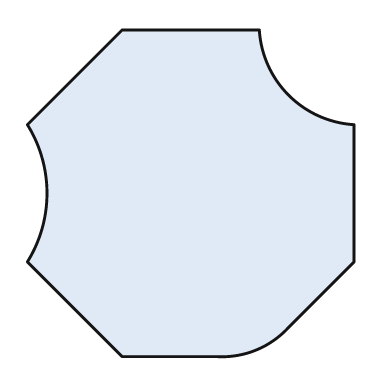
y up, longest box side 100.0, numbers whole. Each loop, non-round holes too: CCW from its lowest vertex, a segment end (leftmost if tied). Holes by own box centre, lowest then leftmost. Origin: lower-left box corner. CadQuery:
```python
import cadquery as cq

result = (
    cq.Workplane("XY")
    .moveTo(29.0, 0.0)
    .lineTo(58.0, 0.0)
    .threePointArc((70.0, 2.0), (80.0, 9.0))
    .lineTo(100.0, 29.0)
    .lineTo(100.0, 71.0)
    .threePointArc((80.0, 80.0), (71.0, 100.0))
    .lineTo(29.0, 100.0)
    .lineTo(0.0, 71.0)
    .threePointArc((6.0, 50.0), (0.0, 29.0))
    .close()
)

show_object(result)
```